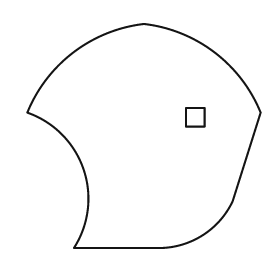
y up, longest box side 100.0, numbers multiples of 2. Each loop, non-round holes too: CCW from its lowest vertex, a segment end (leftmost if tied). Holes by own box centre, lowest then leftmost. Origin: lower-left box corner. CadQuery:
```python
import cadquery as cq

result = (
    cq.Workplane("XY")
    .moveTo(20.0, 0.0)
    .lineTo(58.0, 0.0)
    .threePointArc((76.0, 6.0), (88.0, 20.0))
    .lineTo(100.0, 58.0)
    .threePointArc((80.0, 84.0), (50.0, 96.0))
    .threePointArc((20.0, 84.0), (0.0, 58.0))
    .threePointArc((24.0, 34.0), (20.0, 0.0))
    .close()
    .moveTo(68.0, 52.0)
    .lineTo(76.0, 52.0)
    .lineTo(76.0, 60.0)
    .lineTo(68.0, 60.0)
    .close()
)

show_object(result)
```